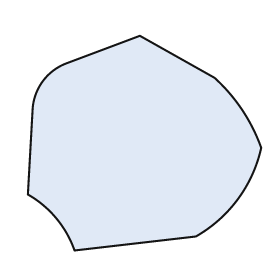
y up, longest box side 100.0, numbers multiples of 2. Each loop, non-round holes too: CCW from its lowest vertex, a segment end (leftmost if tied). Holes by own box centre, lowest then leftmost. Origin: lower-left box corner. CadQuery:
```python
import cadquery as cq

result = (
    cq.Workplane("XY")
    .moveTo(20.0, 0.0)
    .lineTo(72.0, 6.0)
    .threePointArc((90.0, 22.0), (100.0, 44.0))
    .threePointArc((92.0, 60.0), (80.0, 74.0))
    .lineTo(48.0, 92.0)
    .lineTo(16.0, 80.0)
    .threePointArc((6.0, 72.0), (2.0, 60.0))
    .lineTo(0.0, 24.0)
    .threePointArc((12.0, 14.0), (20.0, 0.0))
    .close()
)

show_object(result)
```